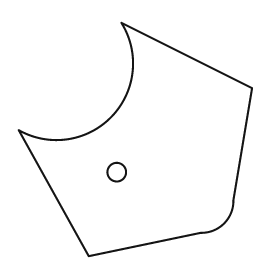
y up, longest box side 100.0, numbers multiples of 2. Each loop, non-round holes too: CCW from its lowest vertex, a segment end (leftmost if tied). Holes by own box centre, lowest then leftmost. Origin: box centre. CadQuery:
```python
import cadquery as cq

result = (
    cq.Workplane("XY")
    .moveTo(-20.0, -50.0)
    .lineTo(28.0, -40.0)
    .threePointArc((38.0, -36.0), (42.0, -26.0))
    .lineTo(50.0, 22.0)
    .lineTo(-6.0, 50.0)
    .threePointArc((-10.0, 10.0), (-50.0, 4.0))
    .close()
    .moveTo(-8.0, -14.0)
    .circle(4.0)
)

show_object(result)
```